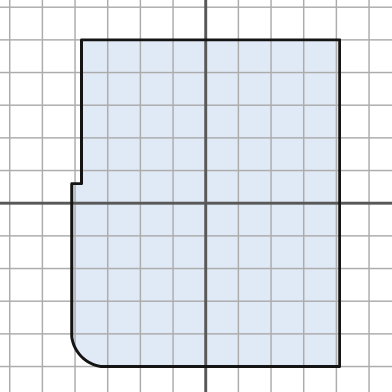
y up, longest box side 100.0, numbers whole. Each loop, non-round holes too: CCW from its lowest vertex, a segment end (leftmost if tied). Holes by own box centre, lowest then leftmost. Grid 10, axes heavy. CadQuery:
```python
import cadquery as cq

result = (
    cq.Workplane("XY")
    .moveTo(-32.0, -50.0)
    .lineTo(41.0, -50.0)
    .lineTo(41.0, 50.0)
    .lineTo(-38.0, 50.0)
    .lineTo(-38.0, 6.0)
    .lineTo(-41.0, 6.0)
    .lineTo(-41.0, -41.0)
    .threePointArc((-38.0, -47.0), (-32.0, -50.0))
    .close()
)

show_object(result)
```